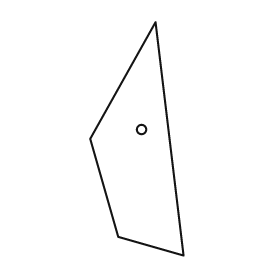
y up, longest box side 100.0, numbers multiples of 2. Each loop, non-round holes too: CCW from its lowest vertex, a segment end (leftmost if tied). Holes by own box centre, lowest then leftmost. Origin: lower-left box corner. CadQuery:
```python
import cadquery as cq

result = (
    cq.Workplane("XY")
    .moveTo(40.0, 0.0)
    .lineTo(28.0, 100.0)
    .lineTo(0.0, 50.0)
    .lineTo(12.0, 8.0)
    .close()
    .moveTo(22.0, 54.0)
    .circle(2.0)
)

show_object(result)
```